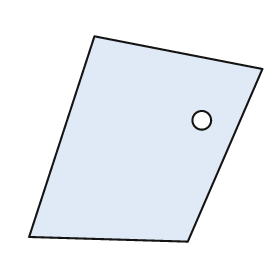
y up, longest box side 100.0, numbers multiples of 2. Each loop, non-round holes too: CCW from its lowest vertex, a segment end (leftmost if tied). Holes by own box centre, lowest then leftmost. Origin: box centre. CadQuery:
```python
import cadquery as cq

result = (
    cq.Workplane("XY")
    .moveTo(18.0, -44.0)
    .lineTo(50.0, 30.0)
    .lineTo(-22.0, 44.0)
    .lineTo(-50.0, -42.0)
    .close()
    .moveTo(24.0, 8.0)
    .circle(4.0)
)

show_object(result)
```